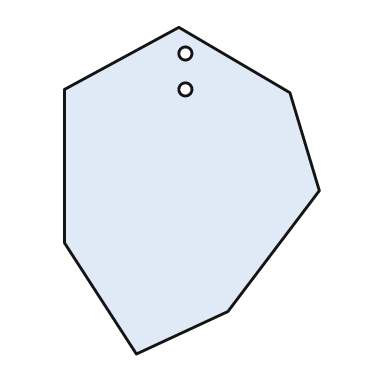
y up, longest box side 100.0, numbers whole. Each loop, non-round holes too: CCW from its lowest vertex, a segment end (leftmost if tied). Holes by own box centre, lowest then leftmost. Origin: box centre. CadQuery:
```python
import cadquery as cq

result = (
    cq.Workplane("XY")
    .moveTo(-17.0, -50.0)
    .lineTo(11.0, -37.0)
    .lineTo(39.0, 0.0)
    .lineTo(30.0, 30.0)
    .lineTo(-4.0, 50.0)
    .lineTo(-39.0, 31.0)
    .lineTo(-39.0, -16.0)
    .close()
    .moveTo(-2.0, 31.0)
    .circle(2.0)
    .moveTo(-2.0, 42.0)
    .circle(2.0)
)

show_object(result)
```